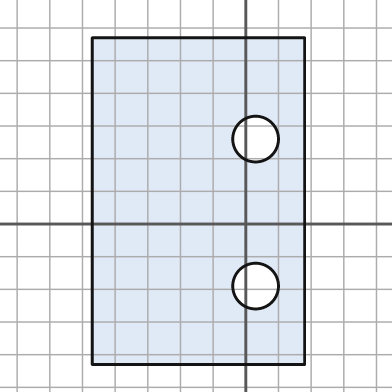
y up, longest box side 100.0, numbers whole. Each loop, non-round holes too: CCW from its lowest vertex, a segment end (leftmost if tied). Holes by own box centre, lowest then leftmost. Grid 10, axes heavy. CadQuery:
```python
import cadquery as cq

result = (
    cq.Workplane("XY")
    .moveTo(-47.0, -43.0)
    .lineTo(18.0, -43.0)
    .lineTo(18.0, 57.0)
    .lineTo(-47.0, 57.0)
    .close()
    .moveTo(3.0, -19.0)
    .circle(7.0)
    .moveTo(3.0, 26.0)
    .circle(7.0)
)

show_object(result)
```